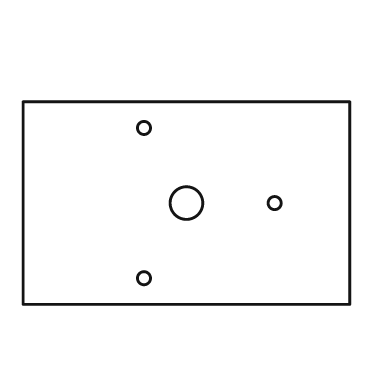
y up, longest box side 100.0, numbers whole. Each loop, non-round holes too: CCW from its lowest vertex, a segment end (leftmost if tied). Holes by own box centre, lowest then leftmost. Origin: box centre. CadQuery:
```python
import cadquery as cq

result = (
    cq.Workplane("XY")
    .moveTo(-50.0, -31.0)
    .lineTo(50.0, -31.0)
    .lineTo(50.0, 31.0)
    .lineTo(-50.0, 31.0)
    .close()
    .moveTo(-13.0, -23.0)
    .circle(2.0)
    .moveTo(0.0, 0.0)
    .circle(5.0)
    .moveTo(27.0, 0.0)
    .circle(2.0)
    .moveTo(-13.0, 23.0)
    .circle(2.0)
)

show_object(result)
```